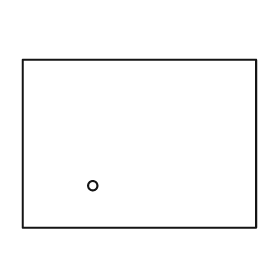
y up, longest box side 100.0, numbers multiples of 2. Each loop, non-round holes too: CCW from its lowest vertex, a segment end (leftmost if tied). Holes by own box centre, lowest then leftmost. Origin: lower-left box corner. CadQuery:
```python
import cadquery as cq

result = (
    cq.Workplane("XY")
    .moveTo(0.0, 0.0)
    .lineTo(100.0, 0.0)
    .lineTo(100.0, 72.0)
    .lineTo(0.0, 72.0)
    .close()
    .moveTo(30.0, 18.0)
    .circle(2.0)
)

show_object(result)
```